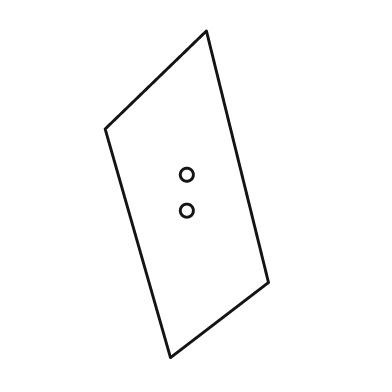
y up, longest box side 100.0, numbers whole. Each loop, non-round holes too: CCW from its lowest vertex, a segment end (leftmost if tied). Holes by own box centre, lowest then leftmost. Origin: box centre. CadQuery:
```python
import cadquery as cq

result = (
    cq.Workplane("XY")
    .moveTo(-5.0, -50.0)
    .lineTo(25.0, -27.0)
    .lineTo(6.0, 50.0)
    .lineTo(-25.0, 20.0)
    .close()
    .moveTo(0.0, -5.0)
    .circle(2.0)
    .moveTo(0.0, 6.0)
    .circle(2.0)
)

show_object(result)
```